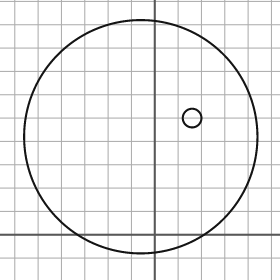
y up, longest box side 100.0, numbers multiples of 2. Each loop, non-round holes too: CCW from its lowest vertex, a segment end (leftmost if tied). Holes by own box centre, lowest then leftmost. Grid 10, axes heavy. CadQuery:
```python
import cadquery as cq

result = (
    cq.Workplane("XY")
    .moveTo(-6.0, 42.0)
    .circle(50.0)
    .moveTo(16.0, 50.0)
    .circle(4.0)
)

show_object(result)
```